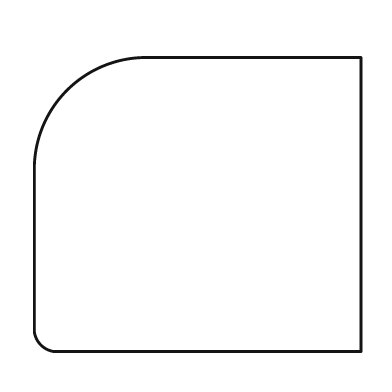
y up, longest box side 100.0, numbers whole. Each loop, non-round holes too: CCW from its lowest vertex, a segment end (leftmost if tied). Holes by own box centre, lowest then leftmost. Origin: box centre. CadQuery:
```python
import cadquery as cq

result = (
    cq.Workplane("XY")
    .moveTo(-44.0, -45.0)
    .lineTo(50.0, -45.0)
    .lineTo(50.0, 45.0)
    .lineTo(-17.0, 45.0)
    .threePointArc((-40.0, 35.0), (-50.0, 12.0))
    .lineTo(-50.0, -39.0)
    .threePointArc((-48.0, -43.0), (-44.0, -45.0))
    .close()
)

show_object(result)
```